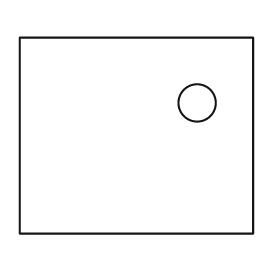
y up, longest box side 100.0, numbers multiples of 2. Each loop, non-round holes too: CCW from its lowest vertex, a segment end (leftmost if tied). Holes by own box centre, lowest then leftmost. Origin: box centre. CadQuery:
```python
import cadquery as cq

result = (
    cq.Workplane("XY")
    .moveTo(-50.0, -42.0)
    .lineTo(50.0, -42.0)
    .lineTo(50.0, 42.0)
    .lineTo(-50.0, 42.0)
    .close()
    .moveTo(26.0, 14.0)
    .circle(8.0)
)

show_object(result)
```